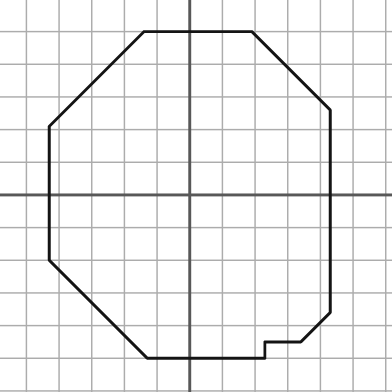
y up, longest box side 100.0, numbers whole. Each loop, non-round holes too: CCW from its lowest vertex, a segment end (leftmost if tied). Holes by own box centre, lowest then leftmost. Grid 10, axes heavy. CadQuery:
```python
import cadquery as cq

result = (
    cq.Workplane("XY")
    .moveTo(-13.0, -50.0)
    .lineTo(23.0, -50.0)
    .lineTo(23.0, -45.0)
    .lineTo(34.0, -45.0)
    .lineTo(43.0, -36.0)
    .lineTo(43.0, 26.0)
    .lineTo(19.0, 50.0)
    .lineTo(-14.0, 50.0)
    .lineTo(-43.0, 21.0)
    .lineTo(-43.0, -20.0)
    .close()
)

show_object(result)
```